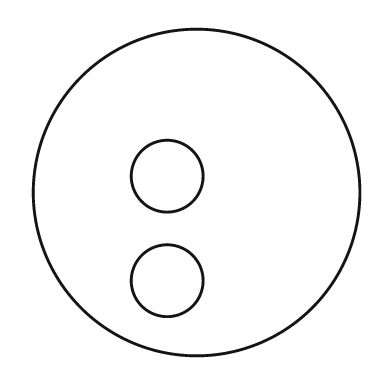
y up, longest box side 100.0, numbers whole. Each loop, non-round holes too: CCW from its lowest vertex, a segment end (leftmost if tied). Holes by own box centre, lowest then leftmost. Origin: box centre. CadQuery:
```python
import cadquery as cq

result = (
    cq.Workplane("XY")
    .moveTo(0.0, 0.0)
    .circle(50.0)
    .moveTo(-9.0, -27.0)
    .circle(11.0)
    .moveTo(-9.0, 5.0)
    .circle(11.0)
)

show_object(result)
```